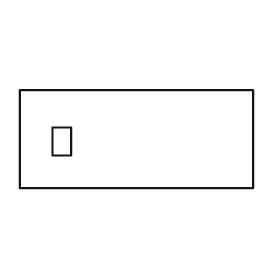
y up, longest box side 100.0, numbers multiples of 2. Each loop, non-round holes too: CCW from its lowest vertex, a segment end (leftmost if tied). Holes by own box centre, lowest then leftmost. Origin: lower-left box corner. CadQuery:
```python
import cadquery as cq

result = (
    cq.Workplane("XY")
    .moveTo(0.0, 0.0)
    .lineTo(100.0, 0.0)
    .lineTo(100.0, 42.0)
    .lineTo(0.0, 42.0)
    .close()
    .moveTo(14.0, 14.0)
    .lineTo(22.0, 14.0)
    .lineTo(22.0, 26.0)
    .lineTo(14.0, 26.0)
    .close()
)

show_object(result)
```